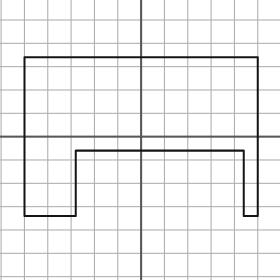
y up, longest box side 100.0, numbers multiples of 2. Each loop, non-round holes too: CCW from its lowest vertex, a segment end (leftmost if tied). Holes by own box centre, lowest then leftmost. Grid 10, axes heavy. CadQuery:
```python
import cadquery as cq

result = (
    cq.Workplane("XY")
    .moveTo(-50.0, -34.0)
    .lineTo(-28.0, -34.0)
    .lineTo(-28.0, -6.0)
    .lineTo(44.0, -6.0)
    .lineTo(44.0, -34.0)
    .lineTo(50.0, -34.0)
    .lineTo(50.0, 34.0)
    .lineTo(-50.0, 34.0)
    .close()
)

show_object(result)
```